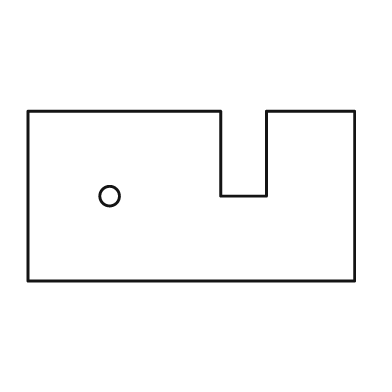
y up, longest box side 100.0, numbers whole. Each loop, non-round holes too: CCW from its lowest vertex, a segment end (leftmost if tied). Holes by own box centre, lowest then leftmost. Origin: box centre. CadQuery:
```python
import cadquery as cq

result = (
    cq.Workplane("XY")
    .moveTo(-50.0, -26.0)
    .lineTo(50.0, -26.0)
    .lineTo(50.0, 26.0)
    .lineTo(23.0, 26.0)
    .lineTo(23.0, 0.0)
    .lineTo(9.0, 0.0)
    .lineTo(9.0, 26.0)
    .lineTo(-50.0, 26.0)
    .close()
    .moveTo(-25.0, 0.0)
    .circle(3.0)
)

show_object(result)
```